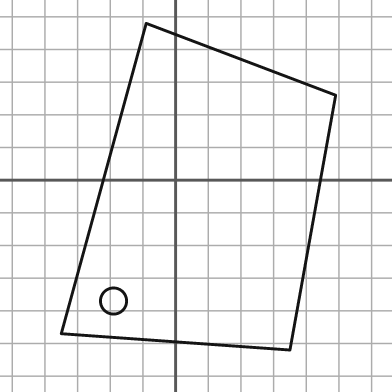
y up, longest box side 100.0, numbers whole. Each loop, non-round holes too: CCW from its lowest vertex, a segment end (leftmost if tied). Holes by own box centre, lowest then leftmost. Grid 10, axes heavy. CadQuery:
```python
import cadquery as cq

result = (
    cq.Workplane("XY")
    .moveTo(35.0, -52.0)
    .lineTo(49.0, 26.0)
    .lineTo(-9.0, 48.0)
    .lineTo(-35.0, -47.0)
    .close()
    .moveTo(-19.0, -37.0)
    .circle(4.0)
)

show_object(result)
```